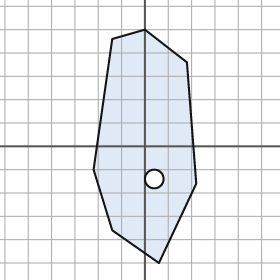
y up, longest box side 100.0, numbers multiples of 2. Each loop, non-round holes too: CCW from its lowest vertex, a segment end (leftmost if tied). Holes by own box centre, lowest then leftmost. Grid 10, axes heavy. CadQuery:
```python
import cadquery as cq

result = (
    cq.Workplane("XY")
    .moveTo(6.0, -50.0)
    .lineTo(22.0, -16.0)
    .lineTo(18.0, 36.0)
    .lineTo(0.0, 50.0)
    .lineTo(-14.0, 46.0)
    .lineTo(-22.0, -10.0)
    .lineTo(-14.0, -36.0)
    .close()
    .moveTo(4.0, -14.0)
    .circle(4.0)
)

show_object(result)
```